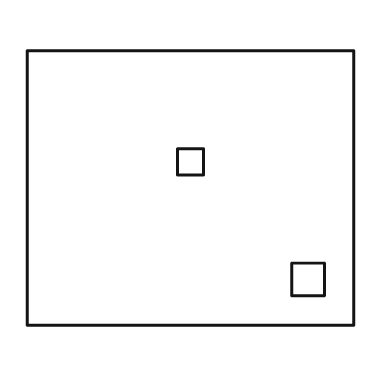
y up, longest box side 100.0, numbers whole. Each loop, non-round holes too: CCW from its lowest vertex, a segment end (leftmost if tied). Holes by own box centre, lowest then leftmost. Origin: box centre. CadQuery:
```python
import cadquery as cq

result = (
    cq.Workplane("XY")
    .moveTo(-50.0, -42.0)
    .lineTo(50.0, -42.0)
    .lineTo(50.0, 42.0)
    .lineTo(-50.0, 42.0)
    .close()
    .moveTo(31.0, -33.0)
    .lineTo(41.0, -33.0)
    .lineTo(41.0, -23.0)
    .lineTo(31.0, -23.0)
    .close()
    .moveTo(-4.0, 4.0)
    .lineTo(4.0, 4.0)
    .lineTo(4.0, 12.0)
    .lineTo(-4.0, 12.0)
    .close()
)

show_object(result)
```